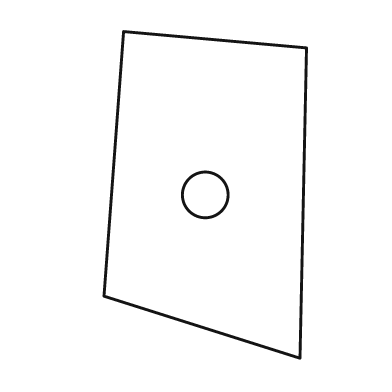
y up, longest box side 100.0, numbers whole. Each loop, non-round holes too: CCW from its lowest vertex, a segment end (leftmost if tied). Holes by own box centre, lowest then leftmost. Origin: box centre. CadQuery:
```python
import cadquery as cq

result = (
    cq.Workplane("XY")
    .moveTo(29.0, -50.0)
    .lineTo(31.0, 45.0)
    .lineTo(-25.0, 50.0)
    .lineTo(-31.0, -31.0)
    .close()
    .moveTo(0.0, 0.0)
    .circle(7.0)
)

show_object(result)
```